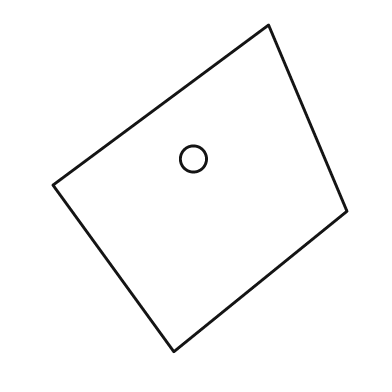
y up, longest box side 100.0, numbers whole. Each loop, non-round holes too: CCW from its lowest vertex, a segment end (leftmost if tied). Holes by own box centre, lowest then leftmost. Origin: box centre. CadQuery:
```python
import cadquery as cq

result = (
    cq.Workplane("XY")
    .moveTo(-8.0, -50.0)
    .lineTo(45.0, -7.0)
    .lineTo(21.0, 50.0)
    .lineTo(-45.0, 1.0)
    .close()
    .moveTo(-2.0, 9.0)
    .circle(4.0)
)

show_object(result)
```